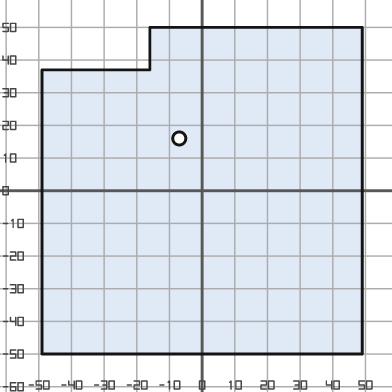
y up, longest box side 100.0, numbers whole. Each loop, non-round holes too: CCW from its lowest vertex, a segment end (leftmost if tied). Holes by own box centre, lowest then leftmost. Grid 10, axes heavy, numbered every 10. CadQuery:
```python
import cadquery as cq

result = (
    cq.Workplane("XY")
    .moveTo(-49.0, -50.0)
    .lineTo(49.0, -50.0)
    .lineTo(49.0, 50.0)
    .lineTo(-16.0, 50.0)
    .lineTo(-16.0, 37.0)
    .lineTo(-49.0, 37.0)
    .close()
    .moveTo(-7.0, 16.0)
    .circle(2.0)
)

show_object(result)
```